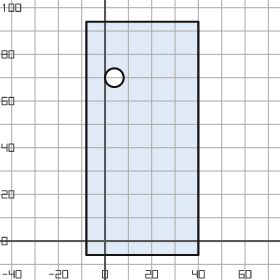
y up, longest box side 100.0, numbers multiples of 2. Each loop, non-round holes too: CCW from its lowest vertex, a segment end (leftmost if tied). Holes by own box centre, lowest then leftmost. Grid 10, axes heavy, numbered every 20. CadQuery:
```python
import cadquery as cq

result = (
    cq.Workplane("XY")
    .moveTo(-8.0, -6.0)
    .lineTo(40.0, -6.0)
    .lineTo(40.0, 94.0)
    .lineTo(-8.0, 94.0)
    .close()
    .moveTo(4.0, 70.0)
    .circle(4.0)
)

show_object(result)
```